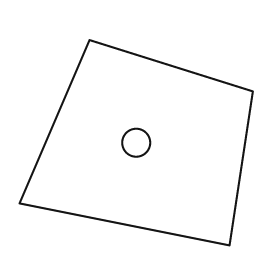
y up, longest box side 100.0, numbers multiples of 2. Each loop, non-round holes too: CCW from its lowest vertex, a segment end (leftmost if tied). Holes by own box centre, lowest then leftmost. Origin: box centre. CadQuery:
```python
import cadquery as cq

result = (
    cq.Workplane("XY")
    .moveTo(40.0, -44.0)
    .lineTo(50.0, 22.0)
    .lineTo(-20.0, 44.0)
    .lineTo(-50.0, -26.0)
    .close()
    .moveTo(0.0, 0.0)
    .circle(6.0)
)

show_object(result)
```